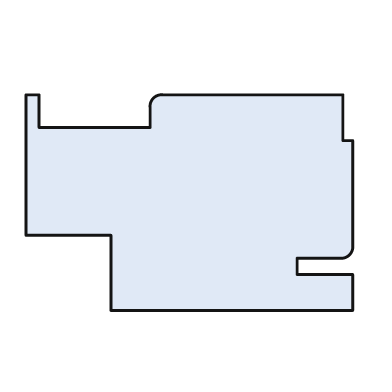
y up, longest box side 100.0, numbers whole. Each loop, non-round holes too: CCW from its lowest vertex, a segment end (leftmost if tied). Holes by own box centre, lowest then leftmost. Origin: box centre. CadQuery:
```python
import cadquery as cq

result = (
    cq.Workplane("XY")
    .moveTo(-24.0, -33.0)
    .lineTo(50.0, -33.0)
    .lineTo(50.0, -22.0)
    .lineTo(33.0, -22.0)
    .lineTo(33.0, -17.0)
    .lineTo(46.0, -17.0)
    .threePointArc((49.0, -16.0), (50.0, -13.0))
    .lineTo(50.0, 19.0)
    .lineTo(47.0, 19.0)
    .lineTo(47.0, 33.0)
    .lineTo(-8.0, 33.0)
    .threePointArc((-11.0, 32.0), (-12.0, 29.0))
    .lineTo(-12.0, 23.0)
    .lineTo(-46.0, 23.0)
    .lineTo(-46.0, 33.0)
    .lineTo(-50.0, 33.0)
    .lineTo(-50.0, -10.0)
    .lineTo(-24.0, -10.0)
    .close()
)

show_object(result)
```